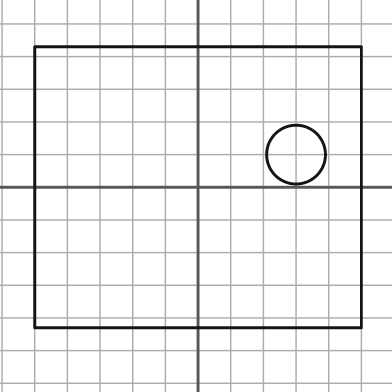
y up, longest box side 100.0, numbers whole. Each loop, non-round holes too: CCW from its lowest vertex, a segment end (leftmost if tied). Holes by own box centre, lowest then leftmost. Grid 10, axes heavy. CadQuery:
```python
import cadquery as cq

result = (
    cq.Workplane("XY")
    .moveTo(-50.0, -43.0)
    .lineTo(50.0, -43.0)
    .lineTo(50.0, 43.0)
    .lineTo(-50.0, 43.0)
    .close()
    .moveTo(30.0, 10.0)
    .circle(9.0)
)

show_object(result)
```